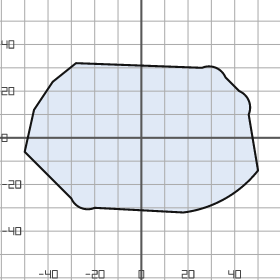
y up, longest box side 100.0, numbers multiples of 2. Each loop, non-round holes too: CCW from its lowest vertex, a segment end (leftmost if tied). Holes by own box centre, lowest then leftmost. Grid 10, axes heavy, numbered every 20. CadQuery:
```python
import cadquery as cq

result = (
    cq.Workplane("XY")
    .moveTo(18.0, -32.0)
    .threePointArc((36.0, -26.0), (50.0, -14.0))
    .lineTo(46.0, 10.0)
    .threePointArc((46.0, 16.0), (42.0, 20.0))
    .lineTo(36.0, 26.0)
    .threePointArc((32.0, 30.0), (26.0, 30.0))
    .lineTo(-28.0, 32.0)
    .lineTo(-38.0, 24.0)
    .lineTo(-46.0, 12.0)
    .lineTo(-50.0, -6.0)
    .lineTo(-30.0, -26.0)
    .threePointArc((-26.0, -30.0), (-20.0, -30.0))
    .close()
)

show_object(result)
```